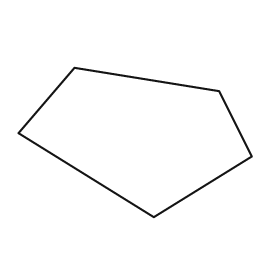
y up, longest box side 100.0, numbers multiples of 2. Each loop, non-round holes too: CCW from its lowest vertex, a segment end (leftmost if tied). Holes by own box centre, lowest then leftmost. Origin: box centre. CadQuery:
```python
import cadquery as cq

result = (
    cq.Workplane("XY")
    .moveTo(8.0, -32.0)
    .lineTo(50.0, -6.0)
    .lineTo(36.0, 22.0)
    .lineTo(-26.0, 32.0)
    .lineTo(-50.0, 4.0)
    .close()
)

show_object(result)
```